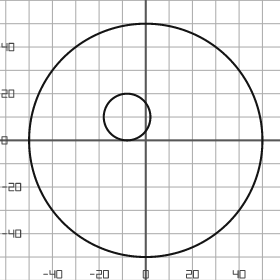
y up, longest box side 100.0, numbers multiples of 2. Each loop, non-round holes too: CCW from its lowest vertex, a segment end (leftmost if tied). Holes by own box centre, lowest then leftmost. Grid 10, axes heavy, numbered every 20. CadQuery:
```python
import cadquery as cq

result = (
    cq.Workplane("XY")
    .moveTo(0.0, 0.0)
    .circle(50.0)
    .moveTo(-8.0, 10.0)
    .circle(10.0)
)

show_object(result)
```